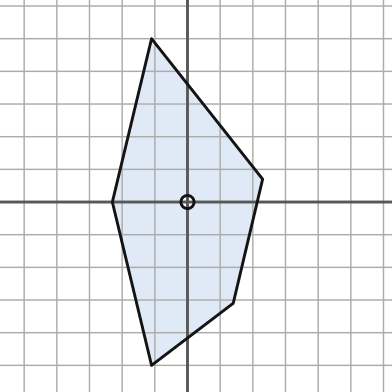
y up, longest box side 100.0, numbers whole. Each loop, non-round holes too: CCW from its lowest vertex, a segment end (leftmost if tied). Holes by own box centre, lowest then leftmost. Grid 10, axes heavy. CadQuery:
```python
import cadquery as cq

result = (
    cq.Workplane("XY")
    .moveTo(-11.0, -50.0)
    .lineTo(14.0, -31.0)
    .lineTo(23.0, 7.0)
    .lineTo(-11.0, 50.0)
    .lineTo(-23.0, 0.0)
    .close()
    .moveTo(0.0, 0.0)
    .circle(2.0)
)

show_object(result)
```